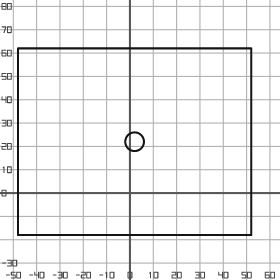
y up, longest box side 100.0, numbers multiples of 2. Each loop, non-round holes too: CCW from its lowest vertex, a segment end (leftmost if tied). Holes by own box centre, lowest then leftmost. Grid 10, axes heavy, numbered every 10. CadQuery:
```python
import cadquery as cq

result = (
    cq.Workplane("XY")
    .moveTo(-48.0, -18.0)
    .lineTo(52.0, -18.0)
    .lineTo(52.0, 62.0)
    .lineTo(-48.0, 62.0)
    .close()
    .moveTo(2.0, 22.0)
    .circle(4.0)
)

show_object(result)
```